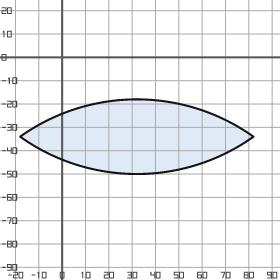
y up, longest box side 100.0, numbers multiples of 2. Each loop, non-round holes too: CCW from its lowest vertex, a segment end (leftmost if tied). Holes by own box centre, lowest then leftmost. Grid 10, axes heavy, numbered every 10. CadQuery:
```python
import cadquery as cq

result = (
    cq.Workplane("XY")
    .moveTo(-18.0, -34.0)
    .threePointArc((32.0, -50.0), (82.0, -34.0))
    .threePointArc((32.0, -18.0), (-18.0, -34.0))
    .close()
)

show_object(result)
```